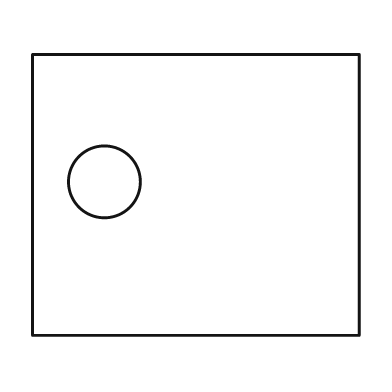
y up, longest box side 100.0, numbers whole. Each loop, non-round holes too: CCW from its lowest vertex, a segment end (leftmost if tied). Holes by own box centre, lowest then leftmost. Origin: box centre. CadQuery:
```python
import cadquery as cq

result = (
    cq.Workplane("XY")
    .moveTo(-50.0, -43.0)
    .lineTo(50.0, -43.0)
    .lineTo(50.0, 43.0)
    .lineTo(-50.0, 43.0)
    .close()
    .moveTo(-28.0, 4.0)
    .circle(11.0)
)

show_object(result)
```